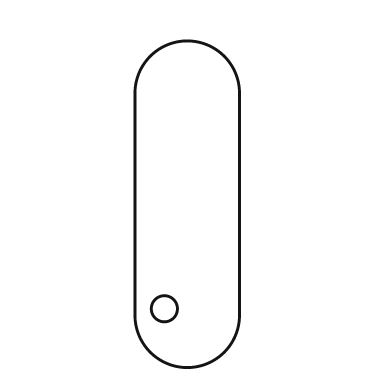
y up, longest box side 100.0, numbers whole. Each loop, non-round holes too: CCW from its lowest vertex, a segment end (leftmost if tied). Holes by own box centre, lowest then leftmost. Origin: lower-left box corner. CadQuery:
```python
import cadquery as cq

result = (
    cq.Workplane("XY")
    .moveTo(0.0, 16.0)
    .threePointArc((16.0, 0.0), (32.0, 16.0))
    .lineTo(32.0, 84.0)
    .threePointArc((16.0, 100.0), (0.0, 84.0))
    .close()
    .moveTo(9.0, 18.0)
    .circle(4.0)
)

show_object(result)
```